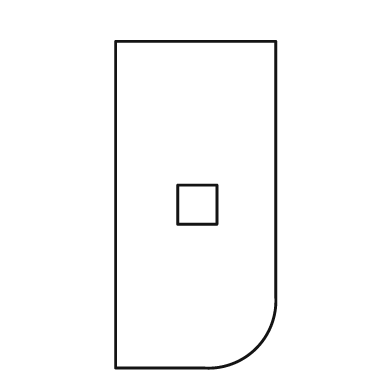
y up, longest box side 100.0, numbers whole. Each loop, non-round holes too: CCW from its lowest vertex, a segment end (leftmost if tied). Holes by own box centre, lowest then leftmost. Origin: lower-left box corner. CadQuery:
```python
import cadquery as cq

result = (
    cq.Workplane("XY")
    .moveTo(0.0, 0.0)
    .lineTo(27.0, 0.0)
    .threePointArc((43.0, 6.0), (49.0, 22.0))
    .lineTo(49.0, 100.0)
    .lineTo(0.0, 100.0)
    .close()
    .moveTo(19.0, 44.0)
    .lineTo(31.0, 44.0)
    .lineTo(31.0, 56.0)
    .lineTo(19.0, 56.0)
    .close()
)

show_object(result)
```